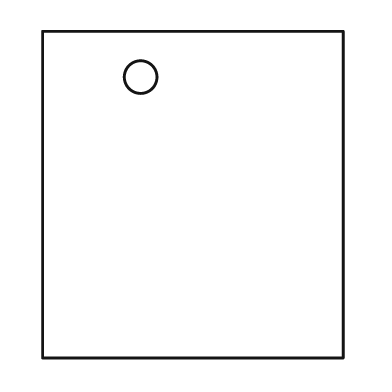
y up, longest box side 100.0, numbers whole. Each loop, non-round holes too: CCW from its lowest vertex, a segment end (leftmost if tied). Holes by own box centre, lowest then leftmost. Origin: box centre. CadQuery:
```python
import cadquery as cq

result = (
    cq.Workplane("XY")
    .moveTo(-46.0, -50.0)
    .lineTo(46.0, -50.0)
    .lineTo(46.0, 50.0)
    .lineTo(-46.0, 50.0)
    .close()
    .moveTo(-16.0, 36.0)
    .circle(5.0)
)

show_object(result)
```